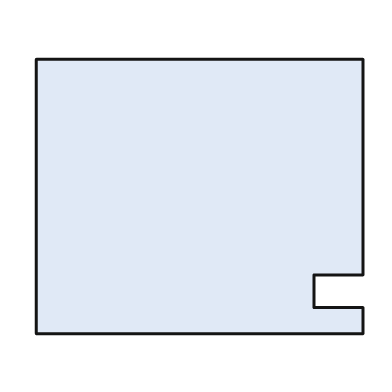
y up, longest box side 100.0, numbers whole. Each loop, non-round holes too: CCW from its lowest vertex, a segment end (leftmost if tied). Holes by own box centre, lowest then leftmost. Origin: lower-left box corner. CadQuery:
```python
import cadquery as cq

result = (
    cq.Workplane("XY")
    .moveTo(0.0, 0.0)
    .lineTo(100.0, 0.0)
    .lineTo(100.0, 8.0)
    .lineTo(85.0, 8.0)
    .lineTo(85.0, 18.0)
    .lineTo(100.0, 18.0)
    .lineTo(100.0, 84.0)
    .lineTo(0.0, 84.0)
    .close()
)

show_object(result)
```